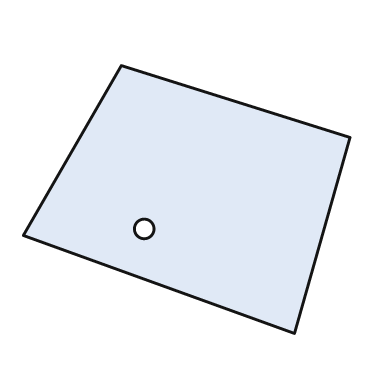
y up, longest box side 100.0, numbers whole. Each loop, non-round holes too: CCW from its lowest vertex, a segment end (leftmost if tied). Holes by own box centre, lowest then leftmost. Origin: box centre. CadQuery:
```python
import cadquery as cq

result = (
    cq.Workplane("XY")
    .moveTo(33.0, -41.0)
    .lineTo(50.0, 19.0)
    .lineTo(-20.0, 41.0)
    .lineTo(-50.0, -11.0)
    .close()
    .moveTo(-13.0, -9.0)
    .circle(3.0)
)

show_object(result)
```